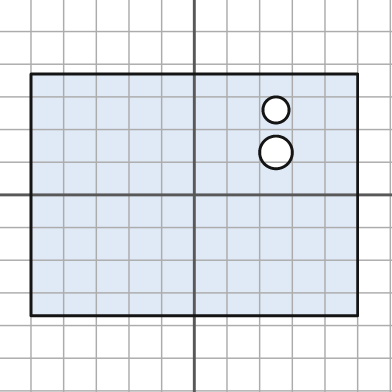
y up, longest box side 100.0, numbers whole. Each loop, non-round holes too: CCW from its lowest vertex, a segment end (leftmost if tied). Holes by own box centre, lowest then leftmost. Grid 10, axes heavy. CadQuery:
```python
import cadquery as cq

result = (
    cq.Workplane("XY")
    .moveTo(-50.0, -37.0)
    .lineTo(50.0, -37.0)
    .lineTo(50.0, 37.0)
    .lineTo(-50.0, 37.0)
    .close()
    .moveTo(25.0, 13.0)
    .circle(5.0)
    .moveTo(25.0, 26.0)
    .circle(4.0)
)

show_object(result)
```